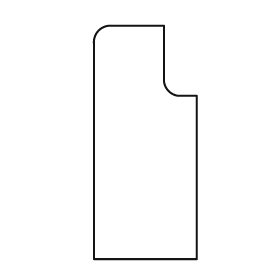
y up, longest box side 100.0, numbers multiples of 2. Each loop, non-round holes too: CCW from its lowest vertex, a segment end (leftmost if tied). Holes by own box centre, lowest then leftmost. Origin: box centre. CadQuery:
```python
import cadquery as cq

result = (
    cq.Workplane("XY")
    .moveTo(-22.0, -50.0)
    .lineTo(22.0, -50.0)
    .lineTo(22.0, 20.0)
    .lineTo(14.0, 20.0)
    .threePointArc((10.0, 22.0), (8.0, 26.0))
    .lineTo(8.0, 50.0)
    .lineTo(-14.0, 50.0)
    .threePointArc((-20.0, 48.0), (-22.0, 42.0))
    .close()
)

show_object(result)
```